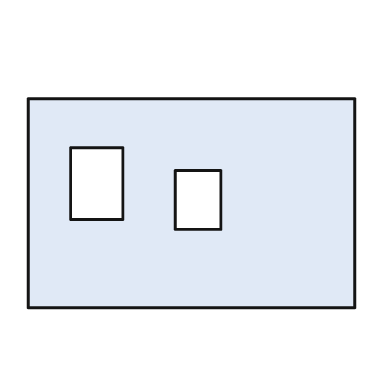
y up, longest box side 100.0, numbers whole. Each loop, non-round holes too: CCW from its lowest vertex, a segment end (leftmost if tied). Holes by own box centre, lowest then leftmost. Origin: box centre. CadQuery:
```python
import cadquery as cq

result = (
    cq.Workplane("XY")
    .moveTo(-50.0, -32.0)
    .lineTo(50.0, -32.0)
    .lineTo(50.0, 32.0)
    .lineTo(-50.0, 32.0)
    .close()
    .moveTo(-5.0, -8.0)
    .lineTo(9.0, -8.0)
    .lineTo(9.0, 10.0)
    .lineTo(-5.0, 10.0)
    .close()
    .moveTo(-37.0, -5.0)
    .lineTo(-21.0, -5.0)
    .lineTo(-21.0, 17.0)
    .lineTo(-37.0, 17.0)
    .close()
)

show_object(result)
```